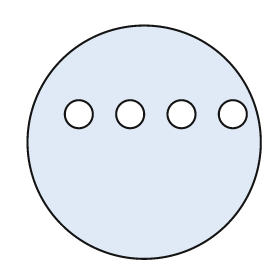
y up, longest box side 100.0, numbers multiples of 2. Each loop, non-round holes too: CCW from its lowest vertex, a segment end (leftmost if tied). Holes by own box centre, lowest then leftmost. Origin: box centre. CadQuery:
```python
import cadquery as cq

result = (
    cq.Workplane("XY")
    .moveTo(0.0, 0.0)
    .circle(50.0)
    .moveTo(-28.0, 12.0)
    .circle(6.0)
    .moveTo(-6.0, 12.0)
    .circle(6.0)
    .moveTo(16.0, 12.0)
    .circle(6.0)
    .moveTo(38.0, 12.0)
    .circle(6.0)
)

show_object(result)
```